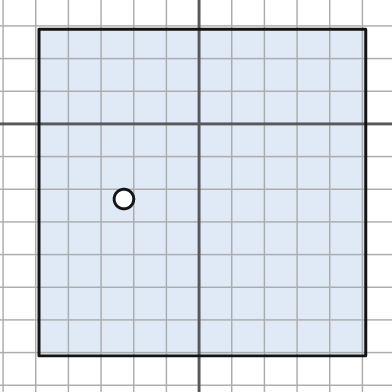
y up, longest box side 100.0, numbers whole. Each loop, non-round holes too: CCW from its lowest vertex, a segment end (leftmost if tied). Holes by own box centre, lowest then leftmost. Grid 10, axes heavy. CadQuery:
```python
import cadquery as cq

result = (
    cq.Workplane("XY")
    .moveTo(-49.0, -71.0)
    .lineTo(51.0, -71.0)
    .lineTo(51.0, 29.0)
    .lineTo(-49.0, 29.0)
    .close()
    .moveTo(-23.0, -23.0)
    .circle(3.0)
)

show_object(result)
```